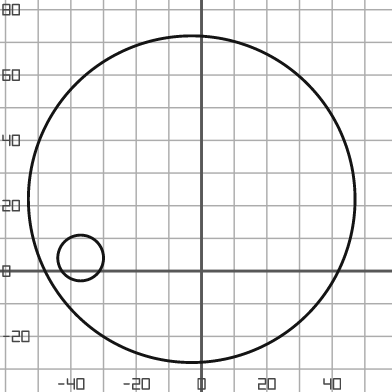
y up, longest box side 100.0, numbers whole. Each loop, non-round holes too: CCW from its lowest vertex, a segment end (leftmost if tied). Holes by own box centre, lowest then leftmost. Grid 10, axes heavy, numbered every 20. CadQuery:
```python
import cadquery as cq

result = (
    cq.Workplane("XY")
    .moveTo(-3.0, 22.0)
    .circle(50.0)
    .moveTo(-37.0, 4.0)
    .circle(7.0)
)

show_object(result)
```